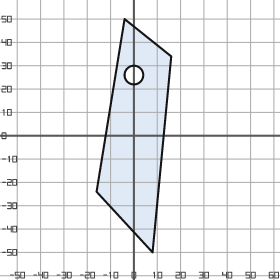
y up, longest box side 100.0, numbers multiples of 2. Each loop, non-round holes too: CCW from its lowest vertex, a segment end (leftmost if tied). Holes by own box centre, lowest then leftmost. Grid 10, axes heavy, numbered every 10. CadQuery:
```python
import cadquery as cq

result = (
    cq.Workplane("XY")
    .moveTo(8.0, -50.0)
    .lineTo(16.0, 34.0)
    .lineTo(-4.0, 50.0)
    .lineTo(-16.0, -24.0)
    .close()
    .moveTo(0.0, 26.0)
    .circle(4.0)
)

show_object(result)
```